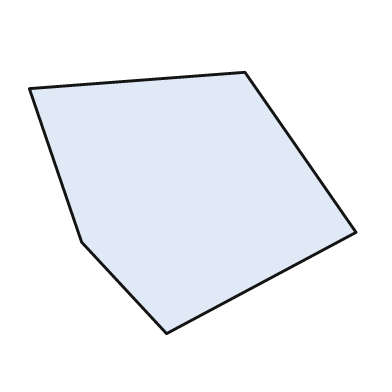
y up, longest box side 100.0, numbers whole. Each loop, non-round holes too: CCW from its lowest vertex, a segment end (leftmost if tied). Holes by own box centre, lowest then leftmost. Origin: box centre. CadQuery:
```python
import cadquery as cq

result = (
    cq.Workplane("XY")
    .moveTo(-8.0, -40.0)
    .lineTo(50.0, -9.0)
    .lineTo(16.0, 40.0)
    .lineTo(-50.0, 35.0)
    .lineTo(-34.0, -12.0)
    .close()
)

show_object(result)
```